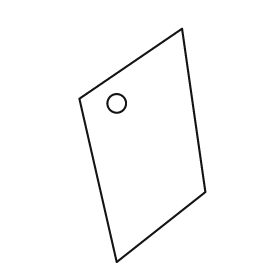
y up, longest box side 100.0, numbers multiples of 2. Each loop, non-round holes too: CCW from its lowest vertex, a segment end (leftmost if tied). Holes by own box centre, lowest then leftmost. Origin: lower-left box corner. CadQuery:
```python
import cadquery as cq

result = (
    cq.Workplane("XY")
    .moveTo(16.0, 0.0)
    .lineTo(54.0, 30.0)
    .lineTo(44.0, 100.0)
    .lineTo(0.0, 70.0)
    .close()
    .moveTo(16.0, 68.0)
    .circle(4.0)
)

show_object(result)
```